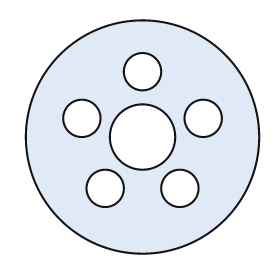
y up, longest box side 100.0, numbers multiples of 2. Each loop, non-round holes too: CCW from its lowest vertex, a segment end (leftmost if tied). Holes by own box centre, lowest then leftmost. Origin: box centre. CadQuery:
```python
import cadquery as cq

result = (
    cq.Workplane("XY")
    .moveTo(0.0, 0.0)
    .circle(50.0)
    .moveTo(-16.0, -22.0)
    .circle(8.0)
    .moveTo(16.0, -22.0)
    .circle(8.0)
    .moveTo(0.0, 0.0)
    .circle(14.0)
    .moveTo(-26.0, 8.0)
    .circle(8.0)
    .moveTo(26.0, 8.0)
    .circle(8.0)
    .moveTo(0.0, 28.0)
    .circle(8.0)
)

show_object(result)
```